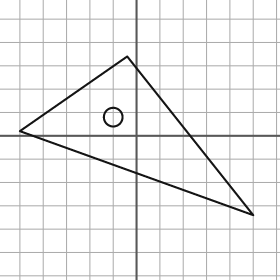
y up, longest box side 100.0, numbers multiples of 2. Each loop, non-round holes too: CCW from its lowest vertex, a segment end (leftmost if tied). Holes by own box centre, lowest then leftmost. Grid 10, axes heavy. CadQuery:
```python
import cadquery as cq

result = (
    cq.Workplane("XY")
    .moveTo(50.0, -34.0)
    .lineTo(-4.0, 34.0)
    .lineTo(-50.0, 2.0)
    .close()
    .moveTo(-10.0, 8.0)
    .circle(4.0)
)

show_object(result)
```